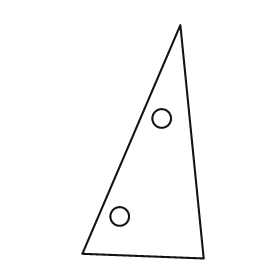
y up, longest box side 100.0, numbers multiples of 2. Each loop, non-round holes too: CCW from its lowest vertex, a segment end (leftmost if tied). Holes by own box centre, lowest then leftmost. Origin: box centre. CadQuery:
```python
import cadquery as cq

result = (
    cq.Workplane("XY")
    .moveTo(26.0, -50.0)
    .lineTo(16.0, 50.0)
    .lineTo(-26.0, -48.0)
    .close()
    .moveTo(-10.0, -32.0)
    .circle(4.0)
    .moveTo(8.0, 10.0)
    .circle(4.0)
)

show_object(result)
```